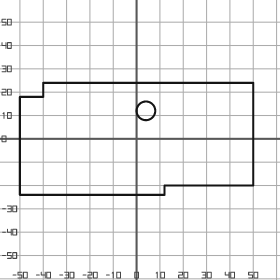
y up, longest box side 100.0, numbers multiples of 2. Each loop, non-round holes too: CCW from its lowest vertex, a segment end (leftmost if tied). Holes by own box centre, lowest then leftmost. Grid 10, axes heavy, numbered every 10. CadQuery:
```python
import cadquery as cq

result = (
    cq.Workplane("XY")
    .moveTo(-50.0, -24.0)
    .lineTo(12.0, -24.0)
    .lineTo(12.0, -20.0)
    .lineTo(50.0, -20.0)
    .lineTo(50.0, 24.0)
    .lineTo(-40.0, 24.0)
    .lineTo(-40.0, 18.0)
    .lineTo(-50.0, 18.0)
    .close()
    .moveTo(4.0, 12.0)
    .circle(4.0)
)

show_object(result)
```